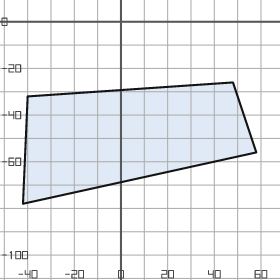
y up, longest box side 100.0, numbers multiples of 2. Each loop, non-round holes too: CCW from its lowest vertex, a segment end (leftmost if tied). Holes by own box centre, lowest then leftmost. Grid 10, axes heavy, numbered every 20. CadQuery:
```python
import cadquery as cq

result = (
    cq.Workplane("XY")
    .moveTo(-42.0, -78.0)
    .lineTo(58.0, -56.0)
    .lineTo(48.0, -26.0)
    .lineTo(-40.0, -32.0)
    .close()
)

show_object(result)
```